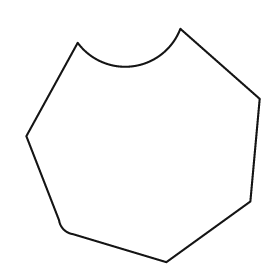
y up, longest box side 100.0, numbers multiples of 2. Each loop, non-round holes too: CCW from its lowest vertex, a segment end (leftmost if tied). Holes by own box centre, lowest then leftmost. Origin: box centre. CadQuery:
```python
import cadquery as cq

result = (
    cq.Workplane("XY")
    .moveTo(10.0, -50.0)
    .lineTo(46.0, -24.0)
    .lineTo(50.0, 20.0)
    .lineTo(16.0, 50.0)
    .threePointArc((-4.0, 34.0), (-28.0, 44.0))
    .lineTo(-50.0, 4.0)
    .lineTo(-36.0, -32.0)
    .threePointArc((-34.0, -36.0), (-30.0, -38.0))
    .close()
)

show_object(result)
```